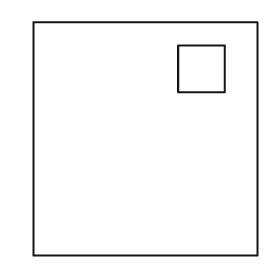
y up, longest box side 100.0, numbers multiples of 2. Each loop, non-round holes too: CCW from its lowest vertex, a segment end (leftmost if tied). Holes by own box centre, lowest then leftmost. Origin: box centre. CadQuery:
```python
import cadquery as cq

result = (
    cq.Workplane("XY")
    .moveTo(-48.0, -50.0)
    .lineTo(48.0, -50.0)
    .lineTo(48.0, 50.0)
    .lineTo(-48.0, 50.0)
    .close()
    .moveTo(14.0, 20.0)
    .lineTo(34.0, 20.0)
    .lineTo(34.0, 40.0)
    .lineTo(14.0, 40.0)
    .close()
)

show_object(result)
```